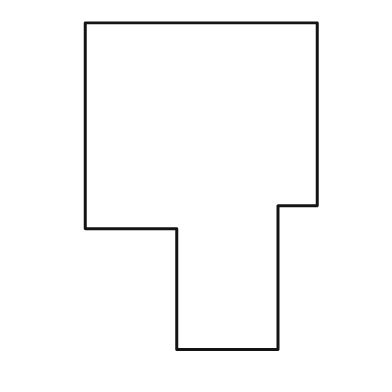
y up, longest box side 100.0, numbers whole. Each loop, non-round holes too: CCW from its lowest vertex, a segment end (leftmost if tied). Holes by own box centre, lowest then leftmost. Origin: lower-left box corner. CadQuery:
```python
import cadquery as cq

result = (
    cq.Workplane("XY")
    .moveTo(28.0, 0.0)
    .lineTo(59.0, 0.0)
    .lineTo(59.0, 44.0)
    .lineTo(71.0, 44.0)
    .lineTo(71.0, 100.0)
    .lineTo(0.0, 100.0)
    .lineTo(0.0, 37.0)
    .lineTo(28.0, 37.0)
    .close()
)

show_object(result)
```